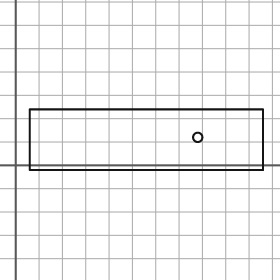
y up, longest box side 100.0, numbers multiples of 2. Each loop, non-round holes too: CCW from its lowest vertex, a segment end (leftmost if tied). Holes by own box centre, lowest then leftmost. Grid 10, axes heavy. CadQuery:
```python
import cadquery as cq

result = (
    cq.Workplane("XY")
    .moveTo(6.0, -2.0)
    .lineTo(106.0, -2.0)
    .lineTo(106.0, 24.0)
    .lineTo(6.0, 24.0)
    .close()
    .moveTo(78.0, 12.0)
    .circle(2.0)
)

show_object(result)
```